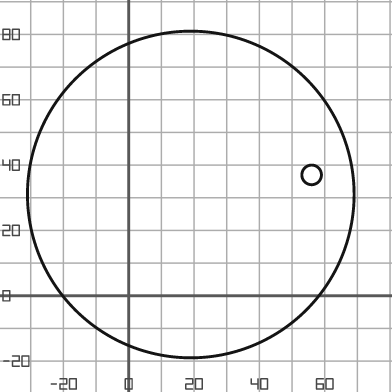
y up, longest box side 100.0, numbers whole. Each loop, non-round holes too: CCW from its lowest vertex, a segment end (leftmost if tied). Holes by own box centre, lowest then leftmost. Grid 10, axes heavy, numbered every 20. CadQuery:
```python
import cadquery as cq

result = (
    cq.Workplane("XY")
    .moveTo(19.0, 31.0)
    .circle(50.0)
    .moveTo(56.0, 37.0)
    .circle(3.0)
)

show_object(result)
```